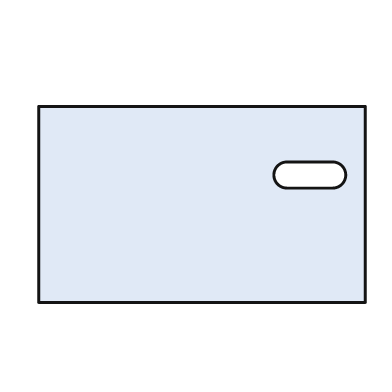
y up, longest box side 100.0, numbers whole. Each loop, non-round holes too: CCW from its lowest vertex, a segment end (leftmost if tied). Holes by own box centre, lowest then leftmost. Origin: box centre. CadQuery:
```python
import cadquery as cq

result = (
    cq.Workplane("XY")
    .moveTo(-50.0, -30.0)
    .lineTo(50.0, -30.0)
    .lineTo(50.0, 30.0)
    .lineTo(-50.0, 30.0)
    .close()
    .moveTo(26.0, 5.0)
    .lineTo(40.0, 5.0)
    .threePointArc((44.0, 9.0), (40.0, 13.0))
    .lineTo(26.0, 13.0)
    .threePointArc((22.0, 9.0), (26.0, 5.0))
    .close()
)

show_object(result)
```